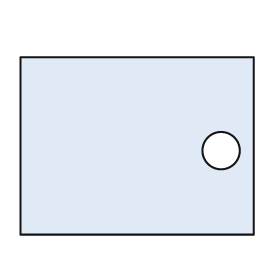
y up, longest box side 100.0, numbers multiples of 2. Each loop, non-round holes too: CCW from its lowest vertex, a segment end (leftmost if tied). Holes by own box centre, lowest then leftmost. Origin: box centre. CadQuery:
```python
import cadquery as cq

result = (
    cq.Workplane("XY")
    .moveTo(-50.0, -38.0)
    .lineTo(50.0, -38.0)
    .lineTo(50.0, 38.0)
    .lineTo(-50.0, 38.0)
    .close()
    .moveTo(36.0, -2.0)
    .circle(8.0)
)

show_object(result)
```